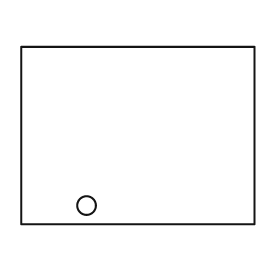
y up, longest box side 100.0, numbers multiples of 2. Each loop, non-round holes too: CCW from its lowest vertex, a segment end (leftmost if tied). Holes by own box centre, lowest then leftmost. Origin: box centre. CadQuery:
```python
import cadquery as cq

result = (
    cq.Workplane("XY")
    .moveTo(-50.0, -38.0)
    .lineTo(50.0, -38.0)
    .lineTo(50.0, 38.0)
    .lineTo(-50.0, 38.0)
    .close()
    .moveTo(-22.0, -30.0)
    .circle(4.0)
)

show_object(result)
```